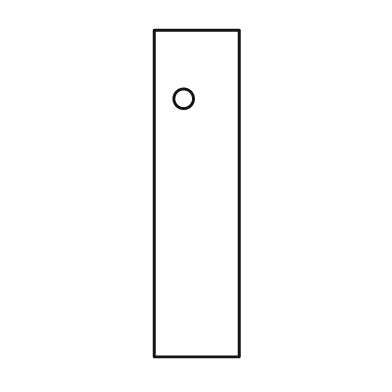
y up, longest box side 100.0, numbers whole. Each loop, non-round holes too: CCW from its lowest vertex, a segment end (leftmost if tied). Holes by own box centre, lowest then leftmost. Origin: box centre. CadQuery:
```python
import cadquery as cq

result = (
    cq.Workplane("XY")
    .moveTo(-13.0, -50.0)
    .lineTo(13.0, -50.0)
    .lineTo(13.0, 50.0)
    .lineTo(-13.0, 50.0)
    .close()
    .moveTo(-4.0, 29.0)
    .circle(3.0)
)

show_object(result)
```